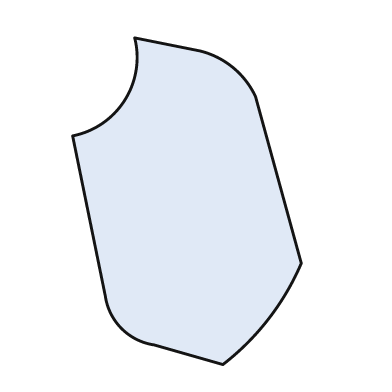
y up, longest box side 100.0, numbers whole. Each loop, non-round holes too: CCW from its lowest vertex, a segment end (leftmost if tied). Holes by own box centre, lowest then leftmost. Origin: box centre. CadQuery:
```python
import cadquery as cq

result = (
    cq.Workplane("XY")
    .moveTo(11.0, -50.0)
    .threePointArc((25.0, -36.0), (35.0, -19.0))
    .lineTo(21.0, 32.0)
    .threePointArc((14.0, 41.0), (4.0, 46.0))
    .lineTo(-16.0, 50.0)
    .threePointArc((-19.0, 31.0), (-35.0, 20.0))
    .lineTo(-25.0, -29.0)
    .threePointArc((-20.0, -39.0), (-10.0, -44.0))
    .close()
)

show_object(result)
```